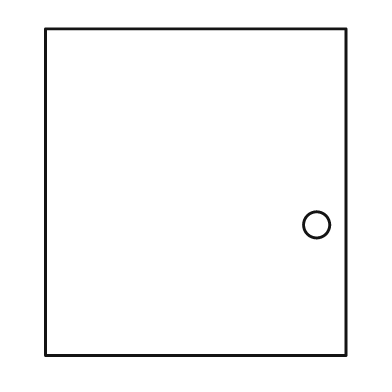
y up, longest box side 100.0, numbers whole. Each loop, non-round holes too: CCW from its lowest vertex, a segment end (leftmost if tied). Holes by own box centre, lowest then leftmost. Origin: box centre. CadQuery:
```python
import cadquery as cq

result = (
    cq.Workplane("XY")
    .moveTo(-46.0, -50.0)
    .lineTo(46.0, -50.0)
    .lineTo(46.0, 50.0)
    .lineTo(-46.0, 50.0)
    .close()
    .moveTo(37.0, -10.0)
    .circle(4.0)
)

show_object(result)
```